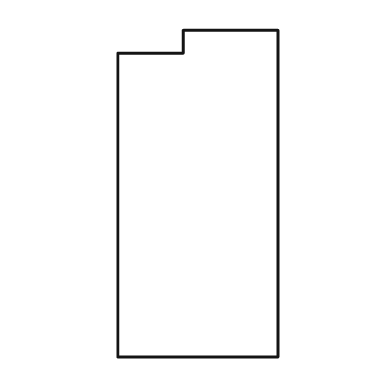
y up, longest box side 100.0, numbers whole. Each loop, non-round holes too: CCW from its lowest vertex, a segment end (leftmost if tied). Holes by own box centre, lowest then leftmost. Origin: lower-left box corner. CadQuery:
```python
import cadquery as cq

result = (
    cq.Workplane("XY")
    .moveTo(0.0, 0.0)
    .lineTo(49.0, 0.0)
    .lineTo(49.0, 100.0)
    .lineTo(20.0, 100.0)
    .lineTo(20.0, 93.0)
    .lineTo(0.0, 93.0)
    .close()
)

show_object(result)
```